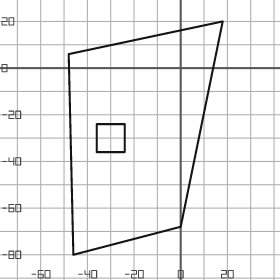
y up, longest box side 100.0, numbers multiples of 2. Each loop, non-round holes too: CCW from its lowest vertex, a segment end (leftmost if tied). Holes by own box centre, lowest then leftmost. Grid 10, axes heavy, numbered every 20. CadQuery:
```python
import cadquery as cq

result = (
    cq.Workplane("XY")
    .moveTo(-46.0, -80.0)
    .lineTo(0.0, -68.0)
    .lineTo(18.0, 20.0)
    .lineTo(-48.0, 6.0)
    .close()
    .moveTo(-36.0, -36.0)
    .lineTo(-24.0, -36.0)
    .lineTo(-24.0, -24.0)
    .lineTo(-36.0, -24.0)
    .close()
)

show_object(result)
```